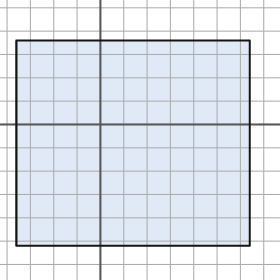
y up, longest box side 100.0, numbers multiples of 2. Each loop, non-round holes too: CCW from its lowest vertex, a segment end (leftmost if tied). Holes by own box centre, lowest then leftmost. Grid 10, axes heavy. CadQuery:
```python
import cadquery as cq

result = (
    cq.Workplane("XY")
    .moveTo(-36.0, -52.0)
    .lineTo(64.0, -52.0)
    .lineTo(64.0, 36.0)
    .lineTo(-36.0, 36.0)
    .close()
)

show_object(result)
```